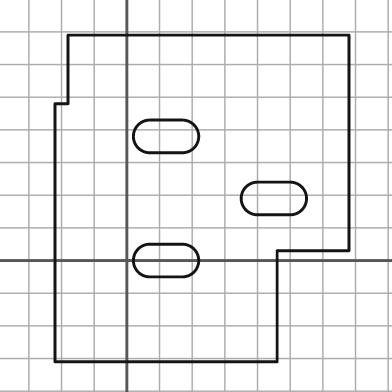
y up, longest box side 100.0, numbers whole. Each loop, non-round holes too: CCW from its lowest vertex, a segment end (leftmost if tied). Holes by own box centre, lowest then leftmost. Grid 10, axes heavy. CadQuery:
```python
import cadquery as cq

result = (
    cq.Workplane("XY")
    .moveTo(-22.0, -31.0)
    .lineTo(46.0, -31.0)
    .lineTo(46.0, 3.0)
    .lineTo(68.0, 3.0)
    .lineTo(68.0, 69.0)
    .lineTo(-18.0, 69.0)
    .lineTo(-18.0, 48.0)
    .lineTo(-22.0, 48.0)
    .close()
    .moveTo(7.0, -5.0)
    .lineTo(17.0, -5.0)
    .threePointArc((22.0, 0.0), (17.0, 5.0))
    .lineTo(7.0, 5.0)
    .threePointArc((2.0, 0.0), (7.0, -5.0))
    .close()
    .moveTo(40.0, 14.0)
    .lineTo(50.0, 14.0)
    .threePointArc((55.0, 19.0), (50.0, 24.0))
    .lineTo(40.0, 24.0)
    .threePointArc((35.0, 19.0), (40.0, 14.0))
    .close()
    .moveTo(7.0, 33.0)
    .lineTo(17.0, 33.0)
    .threePointArc((22.0, 38.0), (17.0, 43.0))
    .lineTo(7.0, 43.0)
    .threePointArc((2.0, 38.0), (7.0, 33.0))
    .close()
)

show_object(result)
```